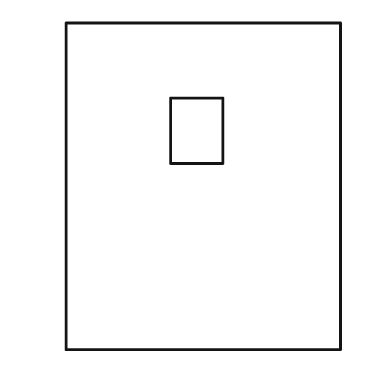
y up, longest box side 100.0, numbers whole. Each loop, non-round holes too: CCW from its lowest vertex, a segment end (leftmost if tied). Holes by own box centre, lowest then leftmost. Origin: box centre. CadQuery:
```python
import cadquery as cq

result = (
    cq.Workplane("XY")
    .moveTo(-42.0, -50.0)
    .lineTo(42.0, -50.0)
    .lineTo(42.0, 50.0)
    .lineTo(-42.0, 50.0)
    .close()
    .moveTo(-10.0, 7.0)
    .lineTo(6.0, 7.0)
    .lineTo(6.0, 27.0)
    .lineTo(-10.0, 27.0)
    .close()
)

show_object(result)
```